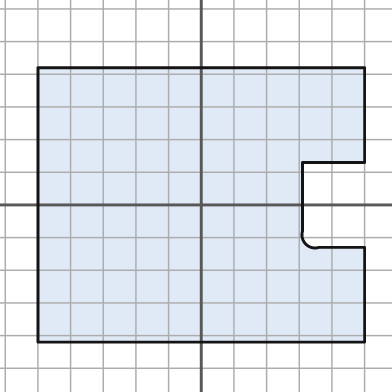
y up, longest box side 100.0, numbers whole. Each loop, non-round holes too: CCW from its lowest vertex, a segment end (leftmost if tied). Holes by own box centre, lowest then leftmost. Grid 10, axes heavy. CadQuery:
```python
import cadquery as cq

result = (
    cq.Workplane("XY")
    .moveTo(-50.0, -42.0)
    .lineTo(50.0, -42.0)
    .lineTo(50.0, -13.0)
    .lineTo(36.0, -13.0)
    .threePointArc((32.0, -12.0), (31.0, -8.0))
    .lineTo(31.0, 13.0)
    .lineTo(50.0, 13.0)
    .lineTo(50.0, 42.0)
    .lineTo(-50.0, 42.0)
    .close()
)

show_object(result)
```